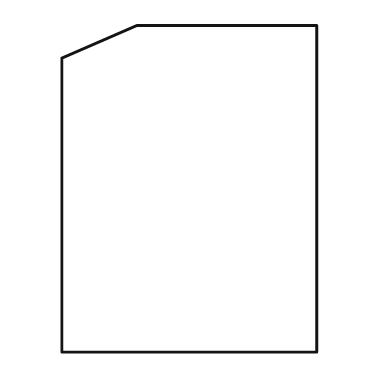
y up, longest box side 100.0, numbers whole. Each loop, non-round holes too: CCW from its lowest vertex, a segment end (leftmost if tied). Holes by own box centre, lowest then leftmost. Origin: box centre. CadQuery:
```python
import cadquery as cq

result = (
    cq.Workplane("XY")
    .moveTo(-39.0, -50.0)
    .lineTo(39.0, -50.0)
    .lineTo(39.0, 50.0)
    .lineTo(-16.0, 50.0)
    .lineTo(-39.0, 40.0)
    .close()
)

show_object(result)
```